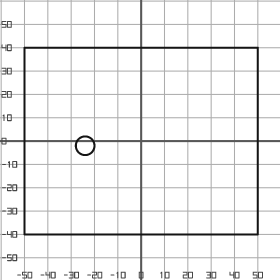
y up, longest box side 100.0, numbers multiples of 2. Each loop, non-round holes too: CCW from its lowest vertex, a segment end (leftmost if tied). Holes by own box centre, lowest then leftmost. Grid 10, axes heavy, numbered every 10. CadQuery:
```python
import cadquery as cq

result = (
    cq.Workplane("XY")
    .moveTo(-50.0, -40.0)
    .lineTo(50.0, -40.0)
    .lineTo(50.0, 40.0)
    .lineTo(-50.0, 40.0)
    .close()
    .moveTo(-24.0, -2.0)
    .circle(4.0)
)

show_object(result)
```